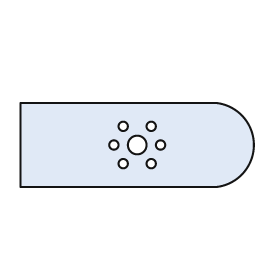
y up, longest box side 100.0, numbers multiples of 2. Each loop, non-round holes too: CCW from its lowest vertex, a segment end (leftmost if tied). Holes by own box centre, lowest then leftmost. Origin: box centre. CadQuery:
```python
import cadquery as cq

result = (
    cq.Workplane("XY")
    .moveTo(-50.0, -18.0)
    .lineTo(34.0, -18.0)
    .threePointArc((50.0, 0.0), (34.0, 18.0))
    .lineTo(-50.0, 18.0)
    .close()
    .moveTo(-6.0, -8.0)
    .circle(2.0)
    .moveTo(6.0, -8.0)
    .circle(2.0)
    .moveTo(-10.0, 0.0)
    .circle(2.0)
    .moveTo(0.0, 0.0)
    .circle(4.0)
    .moveTo(10.0, 0.0)
    .circle(2.0)
    .moveTo(-6.0, 8.0)
    .circle(2.0)
    .moveTo(6.0, 8.0)
    .circle(2.0)
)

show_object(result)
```